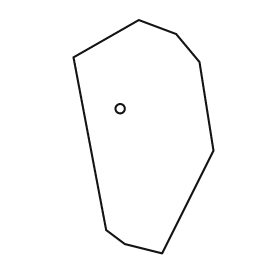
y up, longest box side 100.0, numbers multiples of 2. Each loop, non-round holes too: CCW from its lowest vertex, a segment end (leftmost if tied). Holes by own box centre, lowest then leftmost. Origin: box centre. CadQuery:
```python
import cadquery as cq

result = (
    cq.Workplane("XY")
    .moveTo(8.0, -50.0)
    .lineTo(30.0, -6.0)
    .lineTo(24.0, 32.0)
    .lineTo(14.0, 44.0)
    .lineTo(-2.0, 50.0)
    .lineTo(-30.0, 34.0)
    .lineTo(-16.0, -40.0)
    .lineTo(-8.0, -46.0)
    .close()
    .moveTo(-10.0, 12.0)
    .circle(2.0)
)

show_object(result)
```